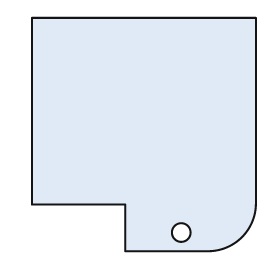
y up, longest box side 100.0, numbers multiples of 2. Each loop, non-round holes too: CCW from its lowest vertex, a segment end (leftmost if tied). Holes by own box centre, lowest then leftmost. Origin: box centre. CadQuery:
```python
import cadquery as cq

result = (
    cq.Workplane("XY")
    .moveTo(-8.0, -50.0)
    .lineTo(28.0, -50.0)
    .threePointArc((42.0, -44.0), (48.0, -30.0))
    .lineTo(48.0, 50.0)
    .lineTo(-48.0, 50.0)
    .lineTo(-48.0, -30.0)
    .lineTo(-8.0, -30.0)
    .close()
    .moveTo(16.0, -42.0)
    .circle(4.0)
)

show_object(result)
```